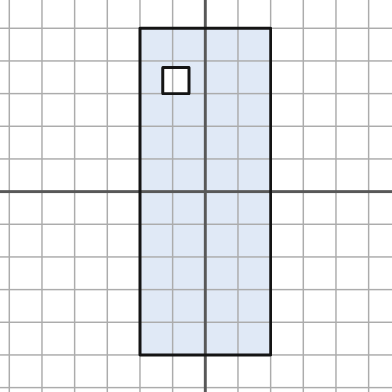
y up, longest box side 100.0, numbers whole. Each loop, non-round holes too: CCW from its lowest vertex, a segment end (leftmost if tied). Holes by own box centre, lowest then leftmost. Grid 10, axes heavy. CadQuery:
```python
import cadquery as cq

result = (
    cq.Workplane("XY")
    .moveTo(-20.0, -50.0)
    .lineTo(20.0, -50.0)
    .lineTo(20.0, 50.0)
    .lineTo(-20.0, 50.0)
    .close()
    .moveTo(-13.0, 30.0)
    .lineTo(-5.0, 30.0)
    .lineTo(-5.0, 38.0)
    .lineTo(-13.0, 38.0)
    .close()
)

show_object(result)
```